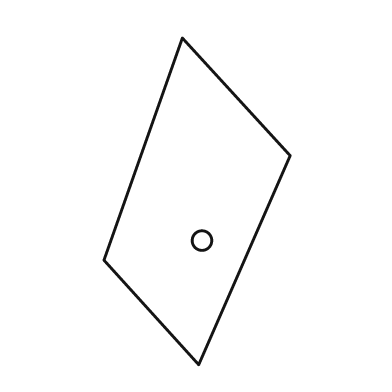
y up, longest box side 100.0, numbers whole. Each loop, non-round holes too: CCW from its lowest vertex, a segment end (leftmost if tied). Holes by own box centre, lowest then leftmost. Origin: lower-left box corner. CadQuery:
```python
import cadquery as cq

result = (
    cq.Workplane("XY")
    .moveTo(29.0, 0.0)
    .lineTo(57.0, 64.0)
    .lineTo(24.0, 100.0)
    .lineTo(0.0, 32.0)
    .close()
    .moveTo(30.0, 38.0)
    .circle(3.0)
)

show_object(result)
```